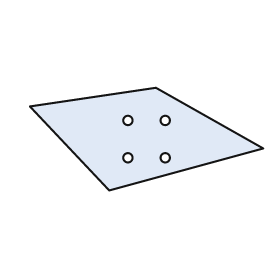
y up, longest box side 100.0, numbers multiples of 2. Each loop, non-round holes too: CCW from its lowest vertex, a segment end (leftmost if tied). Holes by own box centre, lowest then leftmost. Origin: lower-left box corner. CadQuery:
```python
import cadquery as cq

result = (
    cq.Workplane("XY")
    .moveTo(34.0, 0.0)
    .lineTo(100.0, 18.0)
    .lineTo(54.0, 44.0)
    .lineTo(0.0, 36.0)
    .close()
    .moveTo(42.0, 14.0)
    .circle(2.0)
    .moveTo(58.0, 14.0)
    .circle(2.0)
    .moveTo(42.0, 30.0)
    .circle(2.0)
    .moveTo(58.0, 30.0)
    .circle(2.0)
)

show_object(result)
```